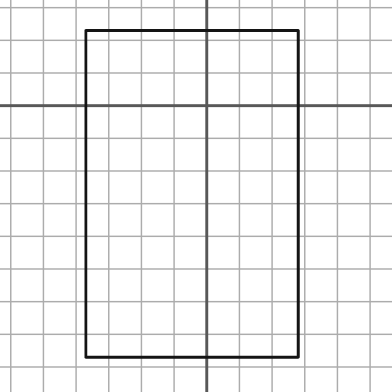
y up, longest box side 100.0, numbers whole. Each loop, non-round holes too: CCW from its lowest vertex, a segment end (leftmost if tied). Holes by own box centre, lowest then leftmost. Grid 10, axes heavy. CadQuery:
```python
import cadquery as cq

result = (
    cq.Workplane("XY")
    .moveTo(-37.0, -77.0)
    .lineTo(28.0, -77.0)
    .lineTo(28.0, 23.0)
    .lineTo(-37.0, 23.0)
    .close()
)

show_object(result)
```